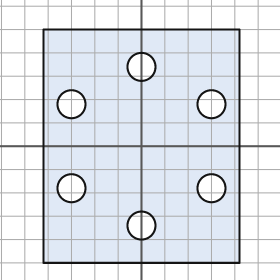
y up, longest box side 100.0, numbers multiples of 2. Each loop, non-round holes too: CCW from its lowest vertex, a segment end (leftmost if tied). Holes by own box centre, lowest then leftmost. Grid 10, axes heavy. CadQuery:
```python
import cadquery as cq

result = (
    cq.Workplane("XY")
    .moveTo(-42.0, -50.0)
    .lineTo(42.0, -50.0)
    .lineTo(42.0, 50.0)
    .lineTo(-42.0, 50.0)
    .close()
    .moveTo(0.0, -34.0)
    .circle(6.0)
    .moveTo(-30.0, -18.0)
    .circle(6.0)
    .moveTo(30.0, -18.0)
    .circle(6.0)
    .moveTo(-30.0, 18.0)
    .circle(6.0)
    .moveTo(30.0, 18.0)
    .circle(6.0)
    .moveTo(0.0, 34.0)
    .circle(6.0)
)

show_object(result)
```